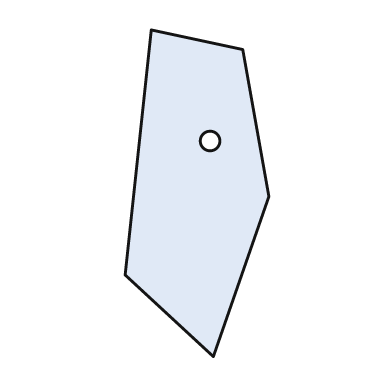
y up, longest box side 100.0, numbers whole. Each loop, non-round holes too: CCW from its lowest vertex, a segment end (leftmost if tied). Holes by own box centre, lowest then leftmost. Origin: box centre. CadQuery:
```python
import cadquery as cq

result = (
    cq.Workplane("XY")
    .moveTo(5.0, -50.0)
    .lineTo(22.0, -1.0)
    .lineTo(14.0, 44.0)
    .lineTo(-14.0, 50.0)
    .lineTo(-22.0, -25.0)
    .close()
    .moveTo(4.0, 16.0)
    .circle(3.0)
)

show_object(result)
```